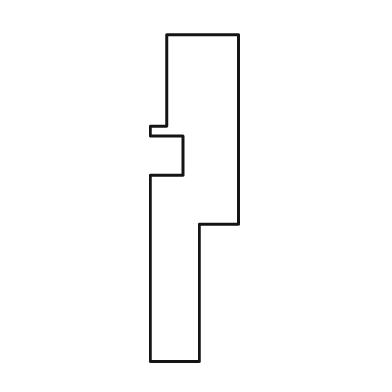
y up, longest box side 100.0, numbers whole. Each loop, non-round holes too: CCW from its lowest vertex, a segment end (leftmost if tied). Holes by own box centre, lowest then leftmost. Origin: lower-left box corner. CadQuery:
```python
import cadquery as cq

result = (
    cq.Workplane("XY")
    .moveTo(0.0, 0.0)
    .lineTo(15.0, 0.0)
    .lineTo(15.0, 42.0)
    .lineTo(27.0, 42.0)
    .lineTo(27.0, 100.0)
    .lineTo(5.0, 100.0)
    .lineTo(5.0, 72.0)
    .lineTo(0.0, 72.0)
    .lineTo(0.0, 69.0)
    .lineTo(10.0, 69.0)
    .lineTo(10.0, 57.0)
    .lineTo(0.0, 57.0)
    .close()
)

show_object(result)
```